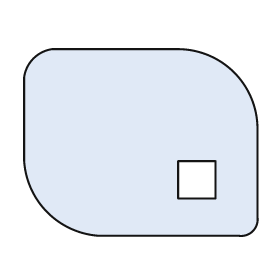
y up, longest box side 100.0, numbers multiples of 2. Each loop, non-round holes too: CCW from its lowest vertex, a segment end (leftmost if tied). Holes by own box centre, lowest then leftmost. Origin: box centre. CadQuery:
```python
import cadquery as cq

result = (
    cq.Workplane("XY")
    .moveTo(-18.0, -40.0)
    .lineTo(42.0, -40.0)
    .threePointArc((48.0, -38.0), (50.0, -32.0))
    .lineTo(50.0, 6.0)
    .threePointArc((40.0, 30.0), (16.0, 40.0))
    .lineTo(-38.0, 40.0)
    .threePointArc((-46.0, 36.0), (-50.0, 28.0))
    .lineTo(-50.0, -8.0)
    .threePointArc((-40.0, -30.0), (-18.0, -40.0))
    .close()
    .moveTo(16.0, -24.0)
    .lineTo(32.0, -24.0)
    .lineTo(32.0, -8.0)
    .lineTo(16.0, -8.0)
    .close()
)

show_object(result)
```